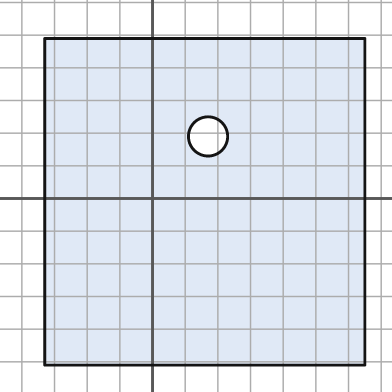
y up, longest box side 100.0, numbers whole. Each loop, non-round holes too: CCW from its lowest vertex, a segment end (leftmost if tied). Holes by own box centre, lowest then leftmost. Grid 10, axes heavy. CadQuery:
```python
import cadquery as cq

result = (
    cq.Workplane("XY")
    .moveTo(-33.0, -51.0)
    .lineTo(65.0, -51.0)
    .lineTo(65.0, 49.0)
    .lineTo(-33.0, 49.0)
    .close()
    .moveTo(17.0, 19.0)
    .circle(6.0)
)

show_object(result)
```